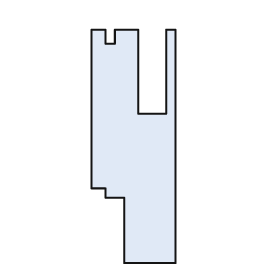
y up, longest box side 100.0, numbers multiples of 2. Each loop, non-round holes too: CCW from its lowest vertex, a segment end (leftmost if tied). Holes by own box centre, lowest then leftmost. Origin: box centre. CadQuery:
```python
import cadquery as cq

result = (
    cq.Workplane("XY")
    .moveTo(-4.0, -50.0)
    .lineTo(18.0, -50.0)
    .lineTo(18.0, 50.0)
    .lineTo(14.0, 50.0)
    .lineTo(14.0, 14.0)
    .lineTo(2.0, 14.0)
    .lineTo(2.0, 50.0)
    .lineTo(-8.0, 50.0)
    .lineTo(-8.0, 44.0)
    .lineTo(-12.0, 44.0)
    .lineTo(-12.0, 50.0)
    .lineTo(-18.0, 50.0)
    .lineTo(-18.0, -18.0)
    .lineTo(-12.0, -18.0)
    .lineTo(-12.0, -22.0)
    .lineTo(-4.0, -22.0)
    .close()
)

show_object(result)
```